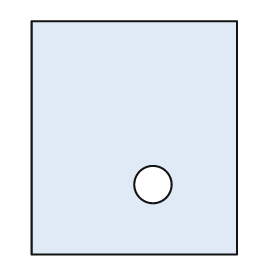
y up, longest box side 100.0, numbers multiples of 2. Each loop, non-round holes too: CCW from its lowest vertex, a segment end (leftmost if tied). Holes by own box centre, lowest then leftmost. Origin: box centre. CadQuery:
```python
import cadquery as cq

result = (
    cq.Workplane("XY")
    .moveTo(-44.0, -50.0)
    .lineTo(44.0, -50.0)
    .lineTo(44.0, 50.0)
    .lineTo(-44.0, 50.0)
    .close()
    .moveTo(8.0, -20.0)
    .circle(8.0)
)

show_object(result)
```